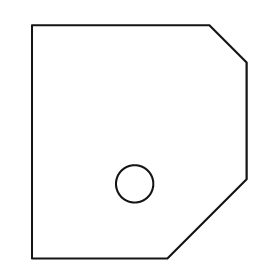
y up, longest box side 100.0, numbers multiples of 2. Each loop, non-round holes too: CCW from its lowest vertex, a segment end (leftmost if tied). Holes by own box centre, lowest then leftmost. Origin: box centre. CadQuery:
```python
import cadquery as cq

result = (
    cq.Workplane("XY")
    .moveTo(-46.0, -50.0)
    .lineTo(12.0, -50.0)
    .lineTo(46.0, -16.0)
    .lineTo(46.0, 34.0)
    .lineTo(30.0, 50.0)
    .lineTo(-46.0, 50.0)
    .close()
    .moveTo(-2.0, -18.0)
    .circle(8.0)
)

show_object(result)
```